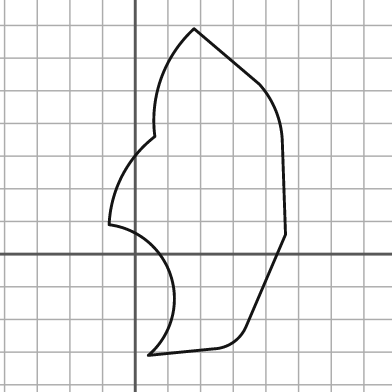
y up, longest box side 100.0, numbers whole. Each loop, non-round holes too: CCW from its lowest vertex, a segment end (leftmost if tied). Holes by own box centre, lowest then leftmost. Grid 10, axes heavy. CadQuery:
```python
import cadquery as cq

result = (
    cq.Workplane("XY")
    .moveTo(4.0, -31.0)
    .lineTo(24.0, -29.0)
    .threePointArc((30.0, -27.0), (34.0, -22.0))
    .lineTo(46.0, 6.0)
    .lineTo(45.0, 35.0)
    .threePointArc((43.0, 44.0), (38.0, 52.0))
    .lineTo(18.0, 69.0)
    .threePointArc((8.0, 54.0), (6.0, 36.0))
    .threePointArc((-4.0, 24.0), (-8.0, 9.0))
    .threePointArc((11.0, -7.0), (4.0, -31.0))
    .close()
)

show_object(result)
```